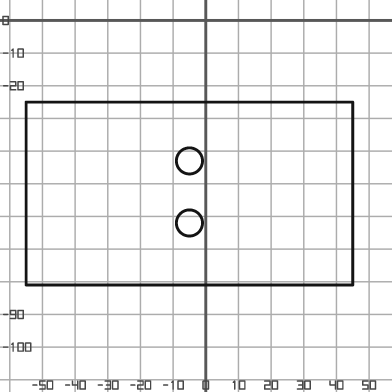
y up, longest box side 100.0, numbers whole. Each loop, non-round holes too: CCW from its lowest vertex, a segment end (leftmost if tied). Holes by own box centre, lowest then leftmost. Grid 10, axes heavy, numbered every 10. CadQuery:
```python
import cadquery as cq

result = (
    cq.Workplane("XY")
    .moveTo(-55.0, -81.0)
    .lineTo(45.0, -81.0)
    .lineTo(45.0, -25.0)
    .lineTo(-55.0, -25.0)
    .close()
    .moveTo(-5.0, -62.0)
    .circle(4.0)
    .moveTo(-5.0, -43.0)
    .circle(4.0)
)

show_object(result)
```